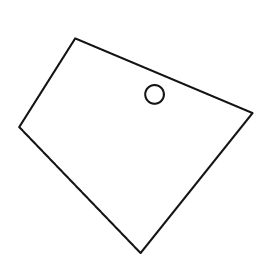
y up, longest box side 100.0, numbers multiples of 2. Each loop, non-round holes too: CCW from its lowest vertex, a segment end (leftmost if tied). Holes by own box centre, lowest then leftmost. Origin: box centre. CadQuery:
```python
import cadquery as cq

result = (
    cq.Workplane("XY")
    .moveTo(2.0, -46.0)
    .lineTo(50.0, 14.0)
    .lineTo(-26.0, 46.0)
    .lineTo(-50.0, 8.0)
    .close()
    .moveTo(8.0, 22.0)
    .circle(4.0)
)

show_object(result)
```